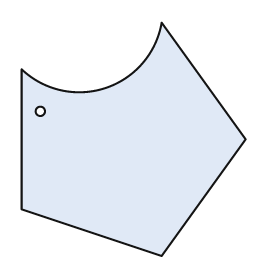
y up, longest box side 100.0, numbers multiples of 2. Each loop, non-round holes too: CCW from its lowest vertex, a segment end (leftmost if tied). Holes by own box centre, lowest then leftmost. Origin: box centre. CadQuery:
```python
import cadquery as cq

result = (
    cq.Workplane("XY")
    .moveTo(12.0, -50.0)
    .lineTo(48.0, 0.0)
    .lineTo(12.0, 50.0)
    .threePointArc((-12.0, 22.0), (-48.0, 30.0))
    .lineTo(-48.0, -30.0)
    .close()
    .moveTo(-40.0, 12.0)
    .circle(2.0)
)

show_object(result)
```